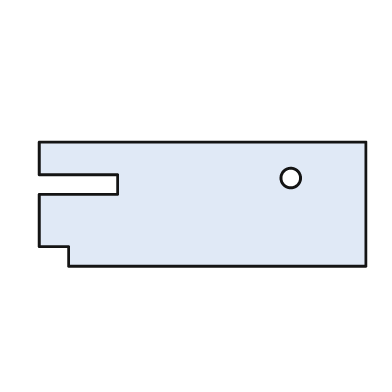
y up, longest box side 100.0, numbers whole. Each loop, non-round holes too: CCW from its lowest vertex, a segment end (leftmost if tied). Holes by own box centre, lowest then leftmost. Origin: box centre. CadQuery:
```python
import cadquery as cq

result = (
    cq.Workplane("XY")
    .moveTo(-41.0, -19.0)
    .lineTo(50.0, -19.0)
    .lineTo(50.0, 19.0)
    .lineTo(-50.0, 19.0)
    .lineTo(-50.0, 9.0)
    .lineTo(-26.0, 9.0)
    .lineTo(-26.0, 3.0)
    .lineTo(-50.0, 3.0)
    .lineTo(-50.0, -13.0)
    .lineTo(-41.0, -13.0)
    .close()
    .moveTo(27.0, 8.0)
    .circle(3.0)
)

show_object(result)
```